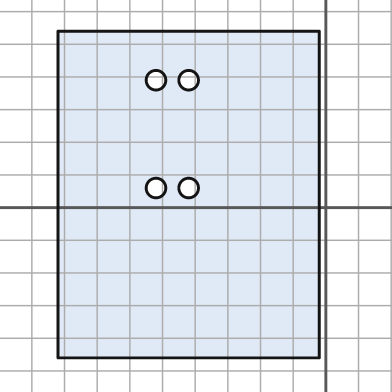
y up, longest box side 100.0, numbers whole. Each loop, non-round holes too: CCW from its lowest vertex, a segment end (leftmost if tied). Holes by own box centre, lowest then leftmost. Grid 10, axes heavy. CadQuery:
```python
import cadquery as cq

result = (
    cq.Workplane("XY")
    .moveTo(-82.0, -46.0)
    .lineTo(-2.0, -46.0)
    .lineTo(-2.0, 54.0)
    .lineTo(-82.0, 54.0)
    .close()
    .moveTo(-52.0, 6.0)
    .circle(3.0)
    .moveTo(-42.0, 6.0)
    .circle(3.0)
    .moveTo(-52.0, 39.0)
    .circle(3.0)
    .moveTo(-42.0, 39.0)
    .circle(3.0)
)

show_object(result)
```